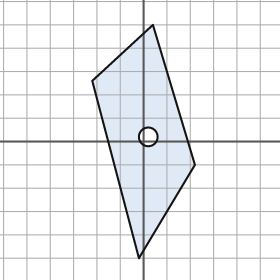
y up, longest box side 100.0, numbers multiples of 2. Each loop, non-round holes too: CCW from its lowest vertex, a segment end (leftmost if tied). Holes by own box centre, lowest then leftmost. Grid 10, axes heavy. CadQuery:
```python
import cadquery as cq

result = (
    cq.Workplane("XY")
    .moveTo(-2.0, -50.0)
    .lineTo(22.0, -10.0)
    .lineTo(4.0, 50.0)
    .lineTo(-22.0, 26.0)
    .close()
    .moveTo(2.0, 2.0)
    .circle(4.0)
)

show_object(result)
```